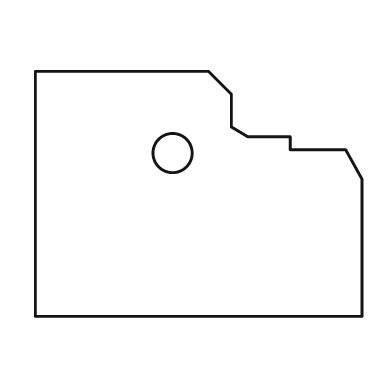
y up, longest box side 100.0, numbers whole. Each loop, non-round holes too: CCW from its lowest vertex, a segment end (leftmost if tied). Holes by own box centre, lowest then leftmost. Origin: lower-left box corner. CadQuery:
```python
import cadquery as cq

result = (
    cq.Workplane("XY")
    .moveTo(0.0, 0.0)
    .lineTo(100.0, 0.0)
    .lineTo(100.0, 42.0)
    .lineTo(95.0, 51.0)
    .lineTo(78.0, 51.0)
    .lineTo(78.0, 55.0)
    .lineTo(65.0, 55.0)
    .lineTo(60.0, 58.0)
    .lineTo(60.0, 68.0)
    .lineTo(53.0, 75.0)
    .lineTo(0.0, 75.0)
    .close()
    .moveTo(42.0, 50.0)
    .circle(6.0)
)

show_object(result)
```